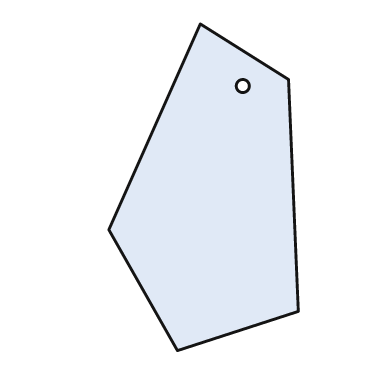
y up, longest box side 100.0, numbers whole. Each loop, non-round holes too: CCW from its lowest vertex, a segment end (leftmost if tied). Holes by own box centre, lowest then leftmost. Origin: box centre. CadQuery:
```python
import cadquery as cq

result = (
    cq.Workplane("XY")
    .moveTo(-8.0, -50.0)
    .lineTo(29.0, -38.0)
    .lineTo(26.0, 33.0)
    .lineTo(-1.0, 50.0)
    .lineTo(-29.0, -13.0)
    .close()
    .moveTo(12.0, 31.0)
    .circle(2.0)
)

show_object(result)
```